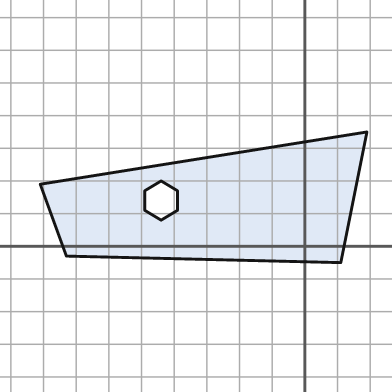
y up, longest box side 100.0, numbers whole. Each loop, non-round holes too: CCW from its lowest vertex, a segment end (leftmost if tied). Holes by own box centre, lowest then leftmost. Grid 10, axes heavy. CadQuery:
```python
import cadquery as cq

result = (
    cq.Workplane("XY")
    .moveTo(11.0, -5.0)
    .lineTo(19.0, 35.0)
    .lineTo(-81.0, 19.0)
    .lineTo(-73.0, -3.0)
    .close()
    .moveTo(-44.0, 8.0)
    .lineTo(-39.0, 11.0)
    .lineTo(-39.0, 17.0)
    .lineTo(-44.0, 20.0)
    .lineTo(-49.0, 17.0)
    .lineTo(-49.0, 11.0)
    .close()
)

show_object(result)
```